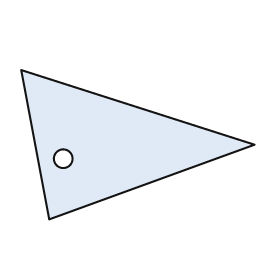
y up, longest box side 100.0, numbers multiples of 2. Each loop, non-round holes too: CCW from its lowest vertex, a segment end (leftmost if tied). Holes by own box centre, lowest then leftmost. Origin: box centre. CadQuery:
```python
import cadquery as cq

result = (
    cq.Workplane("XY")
    .moveTo(-38.0, -32.0)
    .lineTo(50.0, 0.0)
    .lineTo(-50.0, 32.0)
    .close()
    .moveTo(-32.0, -6.0)
    .circle(4.0)
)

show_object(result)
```